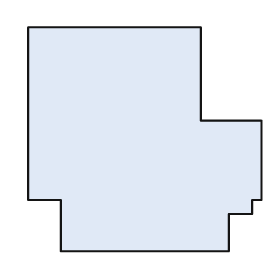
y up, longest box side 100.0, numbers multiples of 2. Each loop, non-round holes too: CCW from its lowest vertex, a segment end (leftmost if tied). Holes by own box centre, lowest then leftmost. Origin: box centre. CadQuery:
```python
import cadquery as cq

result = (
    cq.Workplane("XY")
    .moveTo(-36.0, -48.0)
    .lineTo(36.0, -48.0)
    .lineTo(36.0, -32.0)
    .lineTo(46.0, -32.0)
    .lineTo(46.0, -26.0)
    .lineTo(50.0, -26.0)
    .lineTo(50.0, 8.0)
    .lineTo(24.0, 8.0)
    .lineTo(24.0, 48.0)
    .lineTo(-50.0, 48.0)
    .lineTo(-50.0, -26.0)
    .lineTo(-36.0, -26.0)
    .close()
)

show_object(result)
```